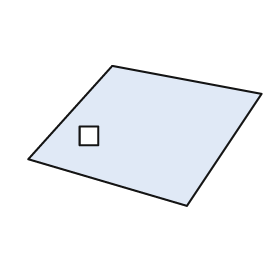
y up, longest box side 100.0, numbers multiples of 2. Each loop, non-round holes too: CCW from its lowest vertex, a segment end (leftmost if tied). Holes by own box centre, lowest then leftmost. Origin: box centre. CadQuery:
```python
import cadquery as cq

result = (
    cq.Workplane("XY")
    .moveTo(18.0, -30.0)
    .lineTo(50.0, 18.0)
    .lineTo(-14.0, 30.0)
    .lineTo(-50.0, -10.0)
    .close()
    .moveTo(-28.0, -4.0)
    .lineTo(-20.0, -4.0)
    .lineTo(-20.0, 4.0)
    .lineTo(-28.0, 4.0)
    .close()
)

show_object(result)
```